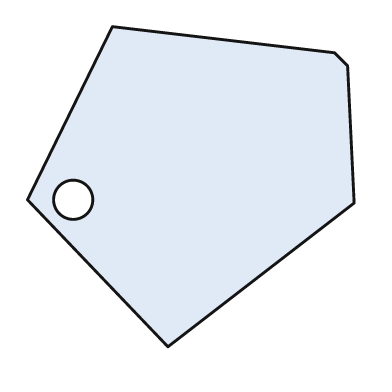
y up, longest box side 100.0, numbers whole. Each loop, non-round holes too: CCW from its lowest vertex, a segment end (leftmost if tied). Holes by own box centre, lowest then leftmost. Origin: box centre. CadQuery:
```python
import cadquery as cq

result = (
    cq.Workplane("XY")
    .moveTo(-7.0, -49.0)
    .lineTo(50.0, -5.0)
    .lineTo(48.0, 37.0)
    .lineTo(44.0, 41.0)
    .lineTo(-24.0, 49.0)
    .lineTo(-50.0, -4.0)
    .close()
    .moveTo(-36.0, -4.0)
    .circle(6.0)
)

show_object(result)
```